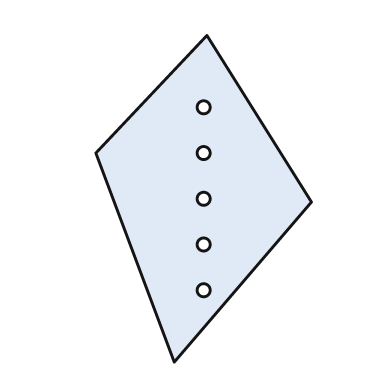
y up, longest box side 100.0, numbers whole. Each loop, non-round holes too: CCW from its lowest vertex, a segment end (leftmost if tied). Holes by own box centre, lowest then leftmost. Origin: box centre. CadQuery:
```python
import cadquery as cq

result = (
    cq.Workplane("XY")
    .moveTo(-9.0, -50.0)
    .lineTo(33.0, -1.0)
    .lineTo(1.0, 50.0)
    .lineTo(-33.0, 14.0)
    .close()
    .moveTo(0.0, -28.0)
    .circle(2.0)
    .moveTo(0.0, -14.0)
    .circle(2.0)
    .moveTo(0.0, 0.0)
    .circle(2.0)
    .moveTo(0.0, 14.0)
    .circle(2.0)
    .moveTo(0.0, 28.0)
    .circle(2.0)
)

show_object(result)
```